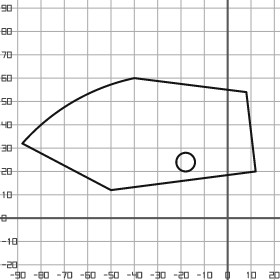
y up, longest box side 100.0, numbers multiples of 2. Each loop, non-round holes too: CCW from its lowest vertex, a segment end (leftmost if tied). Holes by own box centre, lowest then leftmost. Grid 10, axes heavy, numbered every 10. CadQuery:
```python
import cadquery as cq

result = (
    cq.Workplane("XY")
    .moveTo(-50.0, 12.0)
    .lineTo(12.0, 20.0)
    .lineTo(8.0, 54.0)
    .lineTo(-40.0, 60.0)
    .threePointArc((-66.0, 50.0), (-88.0, 32.0))
    .close()
    .moveTo(-18.0, 24.0)
    .circle(4.0)
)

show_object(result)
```